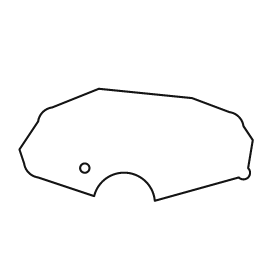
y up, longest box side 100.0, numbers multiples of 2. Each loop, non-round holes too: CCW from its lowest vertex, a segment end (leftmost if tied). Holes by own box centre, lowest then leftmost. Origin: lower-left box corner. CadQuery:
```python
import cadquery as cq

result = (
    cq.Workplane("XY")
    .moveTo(58.0, 0.0)
    .lineTo(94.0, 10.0)
    .threePointArc((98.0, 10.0), (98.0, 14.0))
    .lineTo(100.0, 26.0)
    .lineTo(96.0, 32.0)
    .threePointArc((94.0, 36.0), (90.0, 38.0))
    .lineTo(74.0, 44.0)
    .lineTo(34.0, 48.0)
    .lineTo(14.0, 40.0)
    .threePointArc((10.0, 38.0), (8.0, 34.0))
    .lineTo(0.0, 22.0)
    .lineTo(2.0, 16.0)
    .threePointArc((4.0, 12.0), (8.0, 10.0))
    .lineTo(32.0, 2.0)
    .threePointArc((46.0, 12.0), (58.0, 0.0))
    .close()
    .moveTo(28.0, 14.0)
    .circle(2.0)
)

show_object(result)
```